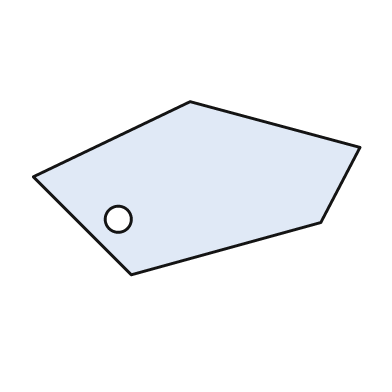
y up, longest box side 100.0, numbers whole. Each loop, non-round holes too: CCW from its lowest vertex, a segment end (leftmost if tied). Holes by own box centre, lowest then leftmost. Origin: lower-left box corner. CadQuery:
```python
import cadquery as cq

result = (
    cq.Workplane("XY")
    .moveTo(30.0, 0.0)
    .lineTo(88.0, 16.0)
    .lineTo(100.0, 39.0)
    .lineTo(48.0, 53.0)
    .lineTo(0.0, 30.0)
    .close()
    .moveTo(26.0, 17.0)
    .circle(4.0)
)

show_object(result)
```